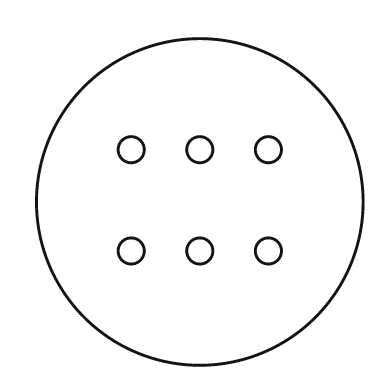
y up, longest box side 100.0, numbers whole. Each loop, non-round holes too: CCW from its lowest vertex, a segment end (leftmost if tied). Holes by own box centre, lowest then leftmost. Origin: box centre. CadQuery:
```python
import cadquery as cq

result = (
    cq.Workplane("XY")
    .moveTo(0.0, 0.0)
    .circle(50.0)
    .moveTo(-21.0, -15.0)
    .circle(4.0)
    .moveTo(0.0, -15.0)
    .circle(4.0)
    .moveTo(21.0, -15.0)
    .circle(4.0)
    .moveTo(-21.0, 16.0)
    .circle(4.0)
    .moveTo(0.0, 16.0)
    .circle(4.0)
    .moveTo(21.0, 16.0)
    .circle(4.0)
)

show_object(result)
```